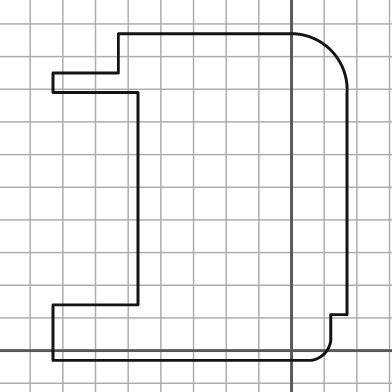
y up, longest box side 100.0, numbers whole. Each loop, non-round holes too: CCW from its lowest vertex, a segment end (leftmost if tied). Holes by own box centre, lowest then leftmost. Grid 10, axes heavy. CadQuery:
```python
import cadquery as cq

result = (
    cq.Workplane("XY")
    .moveTo(-73.0, -3.0)
    .lineTo(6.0, -3.0)
    .threePointArc((10.0, -1.0), (12.0, 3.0))
    .lineTo(12.0, 11.0)
    .lineTo(17.0, 11.0)
    .lineTo(17.0, 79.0)
    .threePointArc((12.0, 92.0), (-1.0, 97.0))
    .lineTo(-53.0, 97.0)
    .lineTo(-53.0, 85.0)
    .lineTo(-73.0, 85.0)
    .lineTo(-73.0, 79.0)
    .lineTo(-47.0, 79.0)
    .lineTo(-47.0, 14.0)
    .lineTo(-73.0, 14.0)
    .close()
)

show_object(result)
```